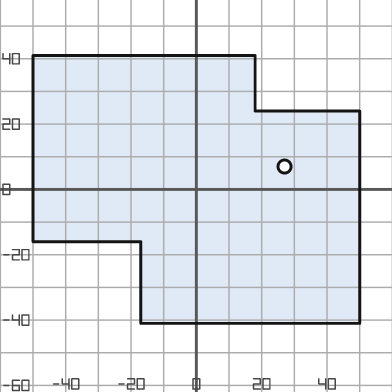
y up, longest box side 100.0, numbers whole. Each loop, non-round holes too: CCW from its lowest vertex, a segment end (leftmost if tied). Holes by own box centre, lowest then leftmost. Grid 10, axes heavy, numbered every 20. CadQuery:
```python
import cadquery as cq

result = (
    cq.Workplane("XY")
    .moveTo(-17.0, -41.0)
    .lineTo(50.0, -41.0)
    .lineTo(50.0, 24.0)
    .lineTo(18.0, 24.0)
    .lineTo(18.0, 41.0)
    .lineTo(-50.0, 41.0)
    .lineTo(-50.0, -16.0)
    .lineTo(-17.0, -16.0)
    .close()
    .moveTo(27.0, 7.0)
    .circle(2.0)
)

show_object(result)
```